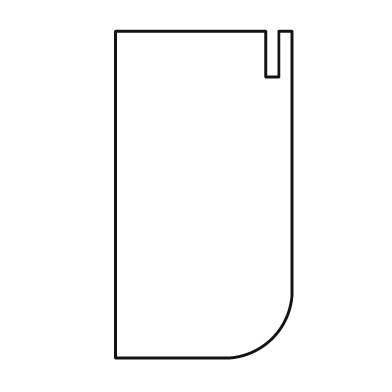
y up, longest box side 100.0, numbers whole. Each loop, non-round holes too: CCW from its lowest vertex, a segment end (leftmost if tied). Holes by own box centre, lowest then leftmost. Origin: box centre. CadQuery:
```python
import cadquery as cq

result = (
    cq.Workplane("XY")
    .moveTo(-27.0, -50.0)
    .lineTo(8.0, -50.0)
    .threePointArc((21.0, -44.0), (27.0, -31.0))
    .lineTo(27.0, 50.0)
    .lineTo(23.0, 50.0)
    .lineTo(23.0, 36.0)
    .lineTo(19.0, 36.0)
    .lineTo(19.0, 50.0)
    .lineTo(-27.0, 50.0)
    .close()
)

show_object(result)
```